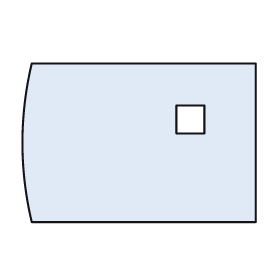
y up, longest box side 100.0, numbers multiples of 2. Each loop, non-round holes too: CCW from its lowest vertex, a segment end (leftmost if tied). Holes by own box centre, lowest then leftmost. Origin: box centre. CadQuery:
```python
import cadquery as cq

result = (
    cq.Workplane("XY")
    .moveTo(-46.0, -34.0)
    .lineTo(50.0, -34.0)
    .lineTo(50.0, 34.0)
    .lineTo(-46.0, 34.0)
    .threePointArc((-50.0, 0.0), (-46.0, -34.0))
    .close()
    .moveTo(16.0, 4.0)
    .lineTo(28.0, 4.0)
    .lineTo(28.0, 16.0)
    .lineTo(16.0, 16.0)
    .close()
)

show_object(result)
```